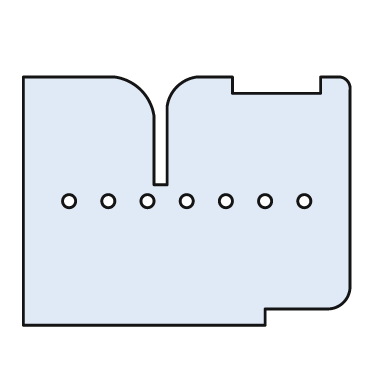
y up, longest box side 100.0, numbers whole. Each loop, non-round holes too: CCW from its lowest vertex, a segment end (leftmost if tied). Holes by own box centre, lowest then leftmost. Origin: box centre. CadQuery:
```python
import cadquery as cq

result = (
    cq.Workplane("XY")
    .moveTo(-50.0, -38.0)
    .lineTo(24.0, -38.0)
    .lineTo(24.0, -33.0)
    .lineTo(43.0, -33.0)
    .threePointArc((48.0, -31.0), (50.0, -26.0))
    .lineTo(50.0, 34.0)
    .threePointArc((49.0, 37.0), (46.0, 38.0))
    .lineTo(41.0, 38.0)
    .lineTo(41.0, 33.0)
    .lineTo(14.0, 33.0)
    .lineTo(14.0, 38.0)
    .lineTo(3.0, 38.0)
    .threePointArc((-3.0, 35.0), (-6.0, 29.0))
    .lineTo(-6.0, 5.0)
    .lineTo(-10.0, 5.0)
    .lineTo(-10.0, 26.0)
    .threePointArc((-14.0, 34.0), (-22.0, 38.0))
    .lineTo(-50.0, 38.0)
    .close()
    .moveTo(-36.0, 0.0)
    .circle(2.0)
    .moveTo(-24.0, 0.0)
    .circle(2.0)
    .moveTo(-12.0, 0.0)
    .circle(2.0)
    .moveTo(0.0, 0.0)
    .circle(2.0)
    .moveTo(12.0, 0.0)
    .circle(2.0)
    .moveTo(24.0, 0.0)
    .circle(2.0)
    .moveTo(36.0, 0.0)
    .circle(2.0)
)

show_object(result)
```